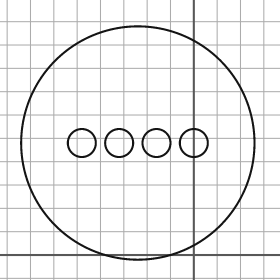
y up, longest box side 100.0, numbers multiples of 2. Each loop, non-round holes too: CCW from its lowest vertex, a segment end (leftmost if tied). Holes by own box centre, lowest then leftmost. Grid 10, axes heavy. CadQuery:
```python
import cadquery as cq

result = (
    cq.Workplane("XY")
    .moveTo(-24.0, 48.0)
    .circle(50.0)
    .moveTo(-48.0, 48.0)
    .circle(6.0)
    .moveTo(-32.0, 48.0)
    .circle(6.0)
    .moveTo(-16.0, 48.0)
    .circle(6.0)
    .moveTo(0.0, 48.0)
    .circle(6.0)
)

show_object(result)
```